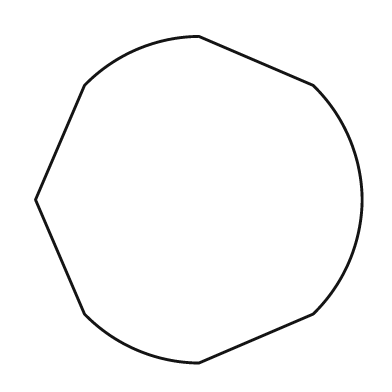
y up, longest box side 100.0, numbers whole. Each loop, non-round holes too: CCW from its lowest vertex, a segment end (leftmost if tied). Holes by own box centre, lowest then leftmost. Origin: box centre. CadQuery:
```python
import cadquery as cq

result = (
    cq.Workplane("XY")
    .moveTo(0.0, -50.0)
    .lineTo(35.0, -35.0)
    .threePointArc((46.0, -19.0), (50.0, 0.0))
    .threePointArc((46.0, 19.0), (35.0, 35.0))
    .lineTo(0.0, 50.0)
    .threePointArc((-19.0, 46.0), (-35.0, 35.0))
    .lineTo(-50.0, 0.0)
    .lineTo(-35.0, -35.0)
    .threePointArc((-19.0, -46.0), (0.0, -50.0))
    .close()
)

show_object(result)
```